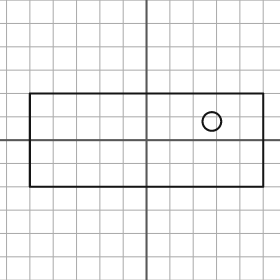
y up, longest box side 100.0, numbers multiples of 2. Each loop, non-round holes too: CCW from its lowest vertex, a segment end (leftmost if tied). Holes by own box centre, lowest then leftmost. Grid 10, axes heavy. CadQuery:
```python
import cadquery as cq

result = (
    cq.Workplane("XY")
    .moveTo(-50.0, -20.0)
    .lineTo(50.0, -20.0)
    .lineTo(50.0, 20.0)
    .lineTo(-50.0, 20.0)
    .close()
    .moveTo(28.0, 8.0)
    .circle(4.0)
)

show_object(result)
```